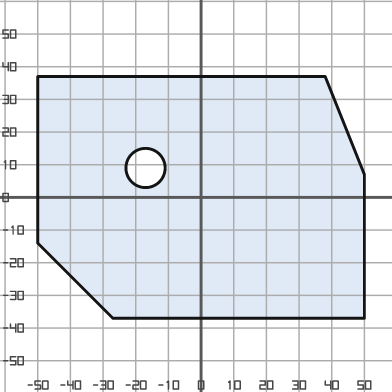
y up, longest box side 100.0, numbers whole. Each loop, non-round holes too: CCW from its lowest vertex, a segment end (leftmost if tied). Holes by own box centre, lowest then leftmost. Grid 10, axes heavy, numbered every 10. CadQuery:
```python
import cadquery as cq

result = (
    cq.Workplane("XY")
    .moveTo(-27.0, -37.0)
    .lineTo(50.0, -37.0)
    .lineTo(50.0, 7.0)
    .lineTo(38.0, 37.0)
    .lineTo(-50.0, 37.0)
    .lineTo(-50.0, -14.0)
    .close()
    .moveTo(-17.0, 9.0)
    .circle(6.0)
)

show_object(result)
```